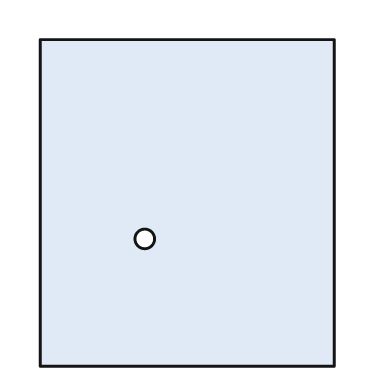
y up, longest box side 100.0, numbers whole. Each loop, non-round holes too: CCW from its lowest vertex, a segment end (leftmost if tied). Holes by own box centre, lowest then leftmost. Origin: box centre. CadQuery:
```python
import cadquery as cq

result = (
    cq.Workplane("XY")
    .moveTo(-45.0, -50.0)
    .lineTo(45.0, -50.0)
    .lineTo(45.0, 50.0)
    .lineTo(-45.0, 50.0)
    .close()
    .moveTo(-13.0, -11.0)
    .circle(3.0)
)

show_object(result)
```